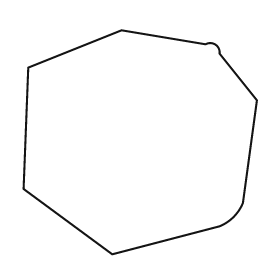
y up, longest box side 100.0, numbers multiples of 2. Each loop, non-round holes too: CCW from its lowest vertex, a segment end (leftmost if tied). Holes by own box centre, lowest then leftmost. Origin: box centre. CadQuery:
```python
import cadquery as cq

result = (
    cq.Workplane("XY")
    .moveTo(-12.0, -48.0)
    .lineTo(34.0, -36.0)
    .threePointArc((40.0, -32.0), (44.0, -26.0))
    .lineTo(50.0, 18.0)
    .lineTo(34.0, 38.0)
    .threePointArc((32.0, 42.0), (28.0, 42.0))
    .lineTo(-8.0, 48.0)
    .lineTo(-48.0, 32.0)
    .lineTo(-50.0, -20.0)
    .close()
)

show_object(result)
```